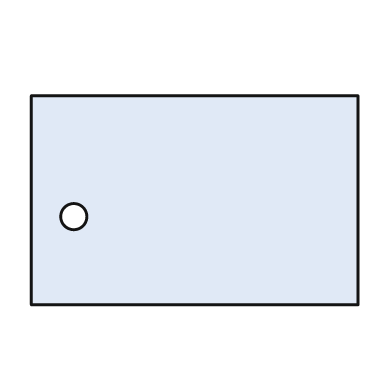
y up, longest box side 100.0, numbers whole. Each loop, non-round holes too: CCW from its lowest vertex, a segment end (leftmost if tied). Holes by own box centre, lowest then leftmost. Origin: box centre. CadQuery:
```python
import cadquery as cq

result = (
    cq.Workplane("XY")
    .moveTo(-50.0, -32.0)
    .lineTo(50.0, -32.0)
    .lineTo(50.0, 32.0)
    .lineTo(-50.0, 32.0)
    .close()
    .moveTo(-37.0, -5.0)
    .circle(4.0)
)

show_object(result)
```